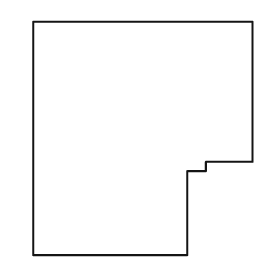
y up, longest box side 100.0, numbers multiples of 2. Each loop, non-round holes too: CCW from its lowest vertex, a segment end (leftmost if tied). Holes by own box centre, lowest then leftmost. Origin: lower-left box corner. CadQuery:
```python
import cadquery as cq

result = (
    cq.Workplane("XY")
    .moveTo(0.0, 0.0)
    .lineTo(66.0, 0.0)
    .lineTo(66.0, 36.0)
    .lineTo(74.0, 36.0)
    .lineTo(74.0, 40.0)
    .lineTo(94.0, 40.0)
    .lineTo(94.0, 100.0)
    .lineTo(0.0, 100.0)
    .close()
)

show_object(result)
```